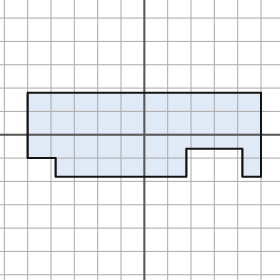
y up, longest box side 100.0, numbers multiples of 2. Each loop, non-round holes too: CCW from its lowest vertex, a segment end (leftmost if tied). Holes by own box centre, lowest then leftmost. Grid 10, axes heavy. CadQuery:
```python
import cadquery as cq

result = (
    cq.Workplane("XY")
    .moveTo(-38.0, -18.0)
    .lineTo(18.0, -18.0)
    .lineTo(18.0, -6.0)
    .lineTo(42.0, -6.0)
    .lineTo(42.0, -18.0)
    .lineTo(50.0, -18.0)
    .lineTo(50.0, 18.0)
    .lineTo(-50.0, 18.0)
    .lineTo(-50.0, -10.0)
    .lineTo(-38.0, -10.0)
    .close()
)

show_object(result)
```